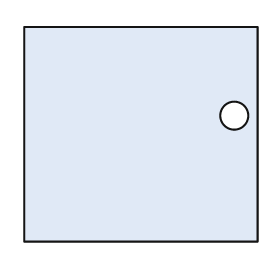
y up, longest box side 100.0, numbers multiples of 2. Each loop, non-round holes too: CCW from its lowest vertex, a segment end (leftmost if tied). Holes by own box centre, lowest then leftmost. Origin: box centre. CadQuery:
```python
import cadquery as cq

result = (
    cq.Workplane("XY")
    .moveTo(-50.0, -46.0)
    .lineTo(50.0, -46.0)
    .lineTo(50.0, 46.0)
    .lineTo(-50.0, 46.0)
    .close()
    .moveTo(40.0, 8.0)
    .circle(6.0)
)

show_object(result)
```